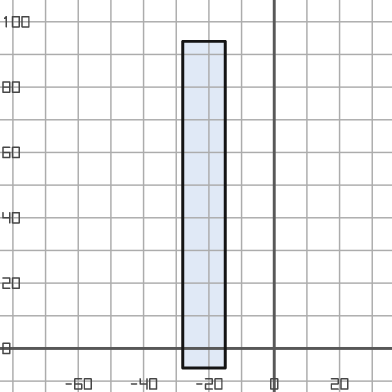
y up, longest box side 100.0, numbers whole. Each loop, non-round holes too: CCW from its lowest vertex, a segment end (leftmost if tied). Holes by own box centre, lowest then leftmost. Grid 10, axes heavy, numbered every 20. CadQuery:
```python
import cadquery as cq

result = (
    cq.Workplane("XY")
    .moveTo(-28.0, -6.0)
    .lineTo(-15.0, -6.0)
    .lineTo(-15.0, 94.0)
    .lineTo(-28.0, 94.0)
    .close()
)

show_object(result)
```